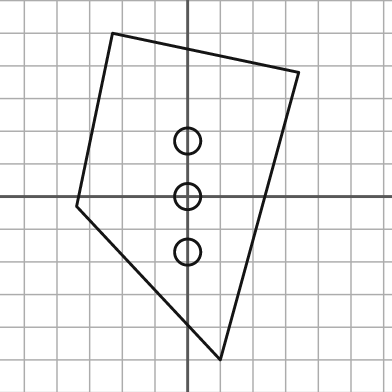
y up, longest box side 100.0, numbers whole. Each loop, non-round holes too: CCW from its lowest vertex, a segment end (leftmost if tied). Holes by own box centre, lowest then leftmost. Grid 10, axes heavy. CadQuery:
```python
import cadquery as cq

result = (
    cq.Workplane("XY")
    .moveTo(10.0, -50.0)
    .lineTo(34.0, 38.0)
    .lineTo(-23.0, 50.0)
    .lineTo(-34.0, -3.0)
    .close()
    .moveTo(0.0, -17.0)
    .circle(4.0)
    .moveTo(0.0, 0.0)
    .circle(4.0)
    .moveTo(0.0, 17.0)
    .circle(4.0)
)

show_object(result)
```